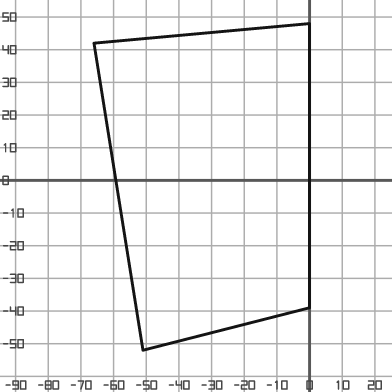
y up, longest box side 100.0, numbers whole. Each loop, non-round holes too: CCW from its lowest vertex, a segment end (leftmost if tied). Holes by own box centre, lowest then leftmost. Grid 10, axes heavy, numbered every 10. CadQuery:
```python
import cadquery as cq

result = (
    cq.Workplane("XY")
    .moveTo(-51.0, -52.0)
    .lineTo(0.0, -39.0)
    .lineTo(0.0, 48.0)
    .lineTo(-66.0, 42.0)
    .close()
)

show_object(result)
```